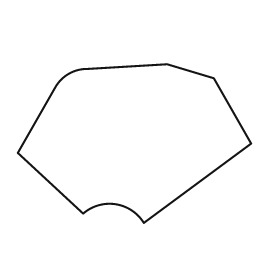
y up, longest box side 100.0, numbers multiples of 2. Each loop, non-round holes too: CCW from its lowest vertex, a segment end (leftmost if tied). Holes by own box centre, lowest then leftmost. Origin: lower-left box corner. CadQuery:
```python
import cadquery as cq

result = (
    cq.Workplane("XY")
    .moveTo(54.0, 0.0)
    .lineTo(100.0, 34.0)
    .lineTo(84.0, 62.0)
    .lineTo(64.0, 68.0)
    .lineTo(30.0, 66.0)
    .threePointArc((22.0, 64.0), (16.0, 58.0))
    .lineTo(0.0, 30.0)
    .lineTo(28.0, 4.0)
    .threePointArc((42.0, 8.0), (54.0, 0.0))
    .close()
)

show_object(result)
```